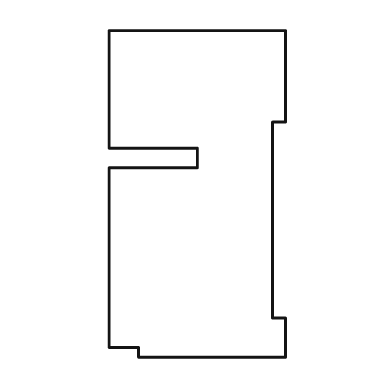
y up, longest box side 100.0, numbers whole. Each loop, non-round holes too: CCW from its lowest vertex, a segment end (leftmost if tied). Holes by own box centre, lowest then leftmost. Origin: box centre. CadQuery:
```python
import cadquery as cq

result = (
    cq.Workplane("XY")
    .moveTo(-18.0, -50.0)
    .lineTo(27.0, -50.0)
    .lineTo(27.0, -38.0)
    .lineTo(23.0, -38.0)
    .lineTo(23.0, 22.0)
    .lineTo(27.0, 22.0)
    .lineTo(27.0, 50.0)
    .lineTo(-27.0, 50.0)
    .lineTo(-27.0, 14.0)
    .lineTo(0.0, 14.0)
    .lineTo(0.0, 8.0)
    .lineTo(-27.0, 8.0)
    .lineTo(-27.0, -47.0)
    .lineTo(-18.0, -47.0)
    .close()
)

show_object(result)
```